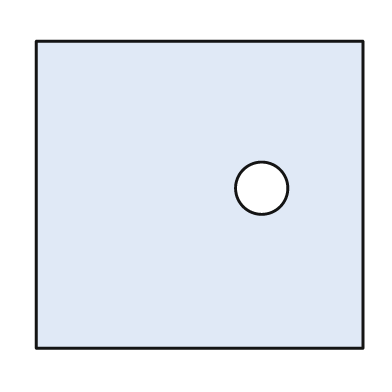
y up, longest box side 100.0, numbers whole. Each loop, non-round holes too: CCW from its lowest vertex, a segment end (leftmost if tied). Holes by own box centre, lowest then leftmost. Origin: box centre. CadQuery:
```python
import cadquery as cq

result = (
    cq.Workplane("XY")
    .moveTo(-50.0, -47.0)
    .lineTo(50.0, -47.0)
    .lineTo(50.0, 47.0)
    .lineTo(-50.0, 47.0)
    .close()
    .moveTo(19.0, 2.0)
    .circle(8.0)
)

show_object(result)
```